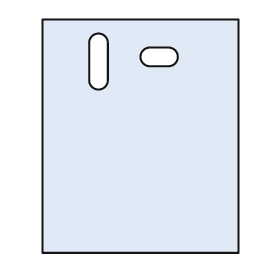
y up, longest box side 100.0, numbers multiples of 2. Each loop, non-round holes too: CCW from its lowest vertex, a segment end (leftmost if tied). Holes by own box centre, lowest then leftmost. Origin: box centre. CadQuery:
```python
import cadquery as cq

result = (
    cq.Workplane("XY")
    .moveTo(-42.0, -50.0)
    .lineTo(42.0, -50.0)
    .lineTo(42.0, 50.0)
    .lineTo(-42.0, 50.0)
    .close()
    .moveTo(-22.0, 24.0)
    .threePointArc((-18.0, 20.0), (-14.0, 24.0))
    .lineTo(-14.0, 40.0)
    .threePointArc((-18.0, 44.0), (-22.0, 40.0))
    .close()
    .moveTo(4.0, 30.0)
    .lineTo(12.0, 30.0)
    .threePointArc((16.0, 34.0), (12.0, 38.0))
    .lineTo(4.0, 38.0)
    .threePointArc((0.0, 34.0), (4.0, 30.0))
    .close()
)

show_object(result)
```